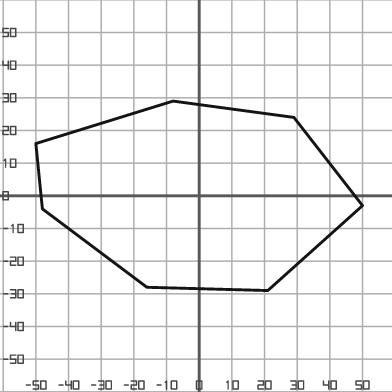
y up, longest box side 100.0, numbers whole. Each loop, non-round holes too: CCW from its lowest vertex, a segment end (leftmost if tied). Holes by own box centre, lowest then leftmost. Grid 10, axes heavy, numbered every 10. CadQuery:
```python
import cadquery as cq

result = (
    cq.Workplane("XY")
    .moveTo(21.0, -29.0)
    .lineTo(50.0, -3.0)
    .lineTo(29.0, 24.0)
    .lineTo(-8.0, 29.0)
    .lineTo(-50.0, 16.0)
    .lineTo(-48.0, -4.0)
    .lineTo(-16.0, -28.0)
    .close()
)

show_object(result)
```